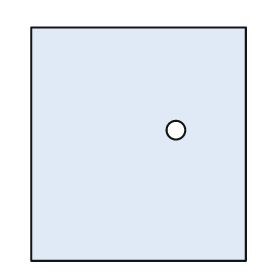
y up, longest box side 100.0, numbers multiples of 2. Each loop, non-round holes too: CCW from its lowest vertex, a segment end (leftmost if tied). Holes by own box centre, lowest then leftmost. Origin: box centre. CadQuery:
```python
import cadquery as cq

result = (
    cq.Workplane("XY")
    .moveTo(-46.0, -50.0)
    .lineTo(46.0, -50.0)
    .lineTo(46.0, 50.0)
    .lineTo(-46.0, 50.0)
    .close()
    .moveTo(16.0, 6.0)
    .circle(4.0)
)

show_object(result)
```